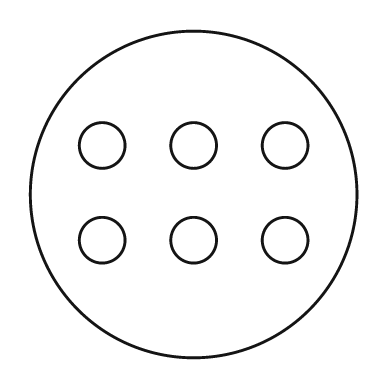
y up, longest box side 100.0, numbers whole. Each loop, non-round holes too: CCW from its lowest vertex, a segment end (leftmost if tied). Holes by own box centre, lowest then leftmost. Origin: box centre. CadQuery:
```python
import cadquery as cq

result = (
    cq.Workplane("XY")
    .moveTo(0.0, 0.0)
    .circle(50.0)
    .moveTo(-28.0, -14.0)
    .circle(7.0)
    .moveTo(0.0, -14.0)
    .circle(7.0)
    .moveTo(28.0, -14.0)
    .circle(7.0)
    .moveTo(-28.0, 15.0)
    .circle(7.0)
    .moveTo(0.0, 15.0)
    .circle(7.0)
    .moveTo(28.0, 15.0)
    .circle(7.0)
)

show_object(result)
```